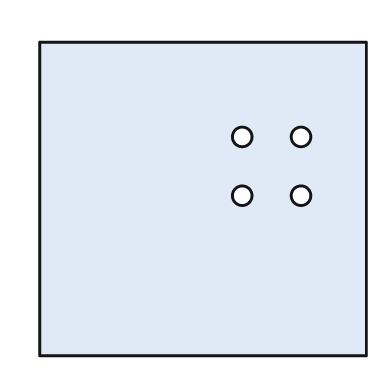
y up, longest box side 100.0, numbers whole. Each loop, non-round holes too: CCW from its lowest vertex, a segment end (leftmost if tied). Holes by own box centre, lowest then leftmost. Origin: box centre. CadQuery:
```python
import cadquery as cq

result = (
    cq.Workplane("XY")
    .moveTo(-50.0, -48.0)
    .lineTo(50.0, -48.0)
    .lineTo(50.0, 48.0)
    .lineTo(-50.0, 48.0)
    .close()
    .moveTo(12.0, 1.0)
    .circle(3.0)
    .moveTo(30.0, 1.0)
    .circle(3.0)
    .moveTo(12.0, 19.0)
    .circle(3.0)
    .moveTo(30.0, 19.0)
    .circle(3.0)
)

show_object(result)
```